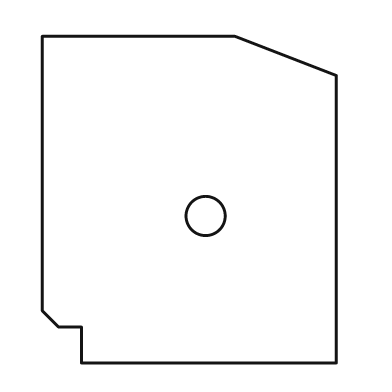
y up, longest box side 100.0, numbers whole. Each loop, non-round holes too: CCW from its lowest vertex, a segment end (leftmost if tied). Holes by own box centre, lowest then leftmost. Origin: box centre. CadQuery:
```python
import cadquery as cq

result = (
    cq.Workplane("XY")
    .moveTo(-33.0, -50.0)
    .lineTo(45.0, -50.0)
    .lineTo(45.0, 38.0)
    .lineTo(14.0, 50.0)
    .lineTo(-45.0, 50.0)
    .lineTo(-45.0, -34.0)
    .lineTo(-40.0, -39.0)
    .lineTo(-33.0, -39.0)
    .close()
    .moveTo(5.0, -5.0)
    .circle(6.0)
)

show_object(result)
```